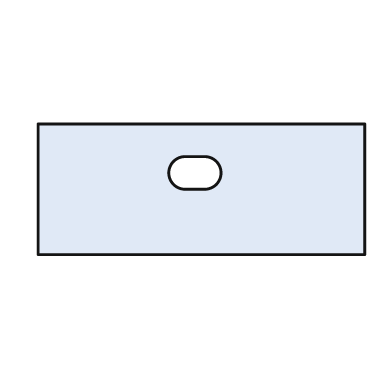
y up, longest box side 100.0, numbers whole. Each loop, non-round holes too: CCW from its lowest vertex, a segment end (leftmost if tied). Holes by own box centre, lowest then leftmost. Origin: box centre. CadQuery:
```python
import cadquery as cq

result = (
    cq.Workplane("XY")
    .moveTo(-50.0, -20.0)
    .lineTo(50.0, -20.0)
    .lineTo(50.0, 20.0)
    .lineTo(-50.0, 20.0)
    .close()
    .moveTo(-5.0, 0.0)
    .lineTo(1.0, 0.0)
    .threePointArc((6.0, 5.0), (1.0, 10.0))
    .lineTo(-5.0, 10.0)
    .threePointArc((-10.0, 5.0), (-5.0, 0.0))
    .close()
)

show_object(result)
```